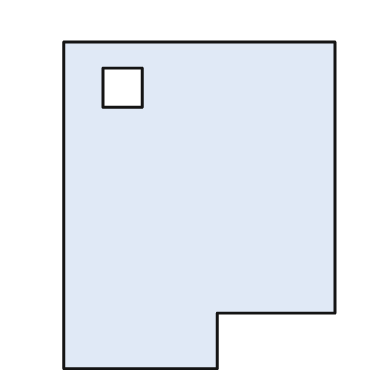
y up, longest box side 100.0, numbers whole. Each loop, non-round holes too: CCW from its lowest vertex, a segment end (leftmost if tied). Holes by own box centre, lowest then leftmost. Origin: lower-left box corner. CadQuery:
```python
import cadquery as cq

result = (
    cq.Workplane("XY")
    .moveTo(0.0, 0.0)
    .lineTo(47.0, 0.0)
    .lineTo(47.0, 17.0)
    .lineTo(83.0, 17.0)
    .lineTo(83.0, 100.0)
    .lineTo(0.0, 100.0)
    .close()
    .moveTo(12.0, 80.0)
    .lineTo(24.0, 80.0)
    .lineTo(24.0, 92.0)
    .lineTo(12.0, 92.0)
    .close()
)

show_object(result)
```